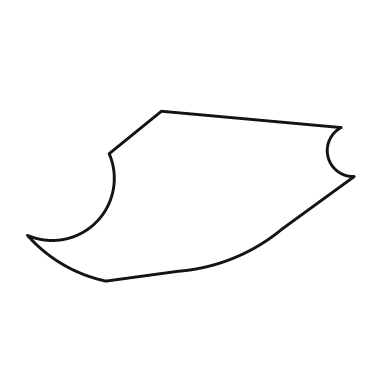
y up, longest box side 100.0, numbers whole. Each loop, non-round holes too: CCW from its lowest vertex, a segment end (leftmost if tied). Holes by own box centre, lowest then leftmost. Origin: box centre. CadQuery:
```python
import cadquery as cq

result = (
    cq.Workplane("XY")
    .moveTo(-26.0, -26.0)
    .lineTo(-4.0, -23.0)
    .threePointArc((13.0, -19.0), (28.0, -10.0))
    .lineTo(50.0, 6.0)
    .threePointArc((42.0, 12.0), (46.0, 21.0))
    .lineTo(-9.0, 26.0)
    .lineTo(-25.0, 13.0)
    .threePointArc((-29.0, -8.0), (-50.0, -12.0))
    .threePointArc((-39.0, -21.0), (-26.0, -26.0))
    .close()
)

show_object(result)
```